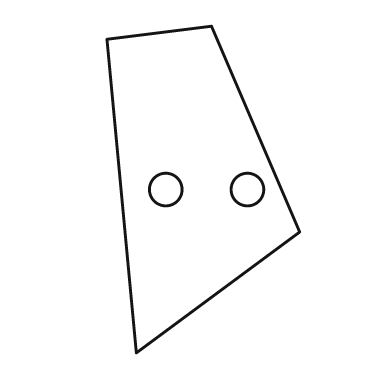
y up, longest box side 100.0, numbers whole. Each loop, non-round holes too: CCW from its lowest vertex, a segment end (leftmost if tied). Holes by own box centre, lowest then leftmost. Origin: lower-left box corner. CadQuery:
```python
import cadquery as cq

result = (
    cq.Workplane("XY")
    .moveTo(9.0, 0.0)
    .lineTo(59.0, 37.0)
    .lineTo(32.0, 100.0)
    .lineTo(0.0, 96.0)
    .close()
    .moveTo(18.0, 50.0)
    .circle(5.0)
    .moveTo(43.0, 50.0)
    .circle(5.0)
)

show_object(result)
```